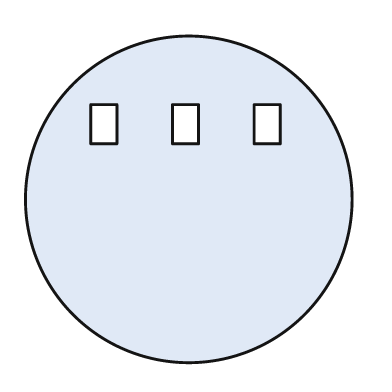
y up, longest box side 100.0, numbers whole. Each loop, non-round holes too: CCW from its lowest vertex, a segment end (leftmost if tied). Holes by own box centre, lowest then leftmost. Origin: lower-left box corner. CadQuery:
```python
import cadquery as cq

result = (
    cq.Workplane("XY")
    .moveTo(50.0, 50.0)
    .circle(50.0)
    .moveTo(20.0, 67.0)
    .lineTo(28.0, 67.0)
    .lineTo(28.0, 79.0)
    .lineTo(20.0, 79.0)
    .close()
    .moveTo(45.0, 67.0)
    .lineTo(53.0, 67.0)
    .lineTo(53.0, 79.0)
    .lineTo(45.0, 79.0)
    .close()
    .moveTo(70.0, 67.0)
    .lineTo(78.0, 67.0)
    .lineTo(78.0, 79.0)
    .lineTo(70.0, 79.0)
    .close()
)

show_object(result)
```